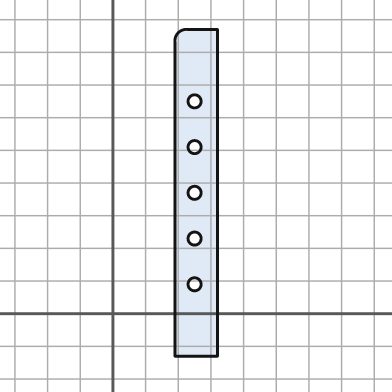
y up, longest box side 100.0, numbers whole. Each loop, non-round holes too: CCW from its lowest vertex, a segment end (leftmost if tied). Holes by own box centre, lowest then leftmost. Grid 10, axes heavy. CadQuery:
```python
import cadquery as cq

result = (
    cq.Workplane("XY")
    .moveTo(19.0, -13.0)
    .lineTo(32.0, -13.0)
    .lineTo(32.0, 87.0)
    .lineTo(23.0, 87.0)
    .threePointArc((20.0, 86.0), (19.0, 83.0))
    .close()
    .moveTo(25.0, 9.0)
    .circle(2.0)
    .moveTo(25.0, 23.0)
    .circle(2.0)
    .moveTo(25.0, 37.0)
    .circle(2.0)
    .moveTo(25.0, 51.0)
    .circle(2.0)
    .moveTo(25.0, 65.0)
    .circle(2.0)
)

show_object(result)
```